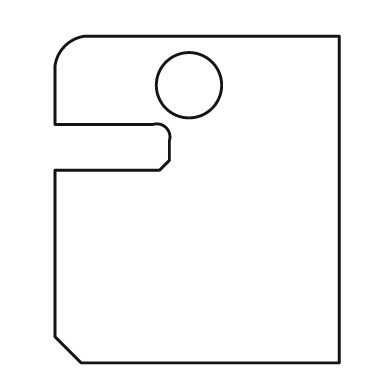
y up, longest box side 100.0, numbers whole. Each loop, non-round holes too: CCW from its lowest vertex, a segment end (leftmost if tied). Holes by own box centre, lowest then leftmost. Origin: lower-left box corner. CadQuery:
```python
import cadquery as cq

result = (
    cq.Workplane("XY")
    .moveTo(8.0, 0.0)
    .lineTo(87.0, 0.0)
    .lineTo(87.0, 100.0)
    .lineTo(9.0, 100.0)
    .threePointArc((3.0, 97.0), (0.0, 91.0))
    .lineTo(0.0, 73.0)
    .lineTo(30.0, 73.0)
    .threePointArc((34.0, 72.0), (35.0, 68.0))
    .lineTo(35.0, 62.0)
    .lineTo(32.0, 59.0)
    .lineTo(0.0, 59.0)
    .lineTo(0.0, 8.0)
    .close()
    .moveTo(41.0, 85.0)
    .circle(10.0)
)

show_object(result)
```